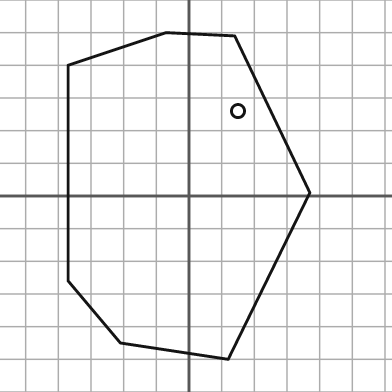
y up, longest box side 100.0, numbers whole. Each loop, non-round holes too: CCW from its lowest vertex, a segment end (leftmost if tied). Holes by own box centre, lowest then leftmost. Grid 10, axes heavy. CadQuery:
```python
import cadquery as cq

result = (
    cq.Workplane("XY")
    .moveTo(12.0, -50.0)
    .lineTo(37.0, 1.0)
    .lineTo(14.0, 49.0)
    .lineTo(-7.0, 50.0)
    .lineTo(-37.0, 40.0)
    .lineTo(-37.0, -26.0)
    .lineTo(-21.0, -45.0)
    .close()
    .moveTo(15.0, 26.0)
    .circle(2.0)
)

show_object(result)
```